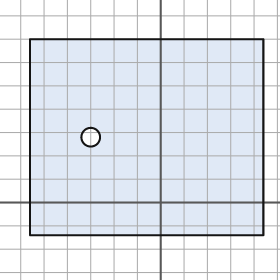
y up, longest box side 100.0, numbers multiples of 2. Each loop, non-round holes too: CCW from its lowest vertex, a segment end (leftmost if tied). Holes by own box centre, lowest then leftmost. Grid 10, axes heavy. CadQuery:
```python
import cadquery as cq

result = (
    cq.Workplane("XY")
    .moveTo(-56.0, -14.0)
    .lineTo(44.0, -14.0)
    .lineTo(44.0, 70.0)
    .lineTo(-56.0, 70.0)
    .close()
    .moveTo(-30.0, 28.0)
    .circle(4.0)
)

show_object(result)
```